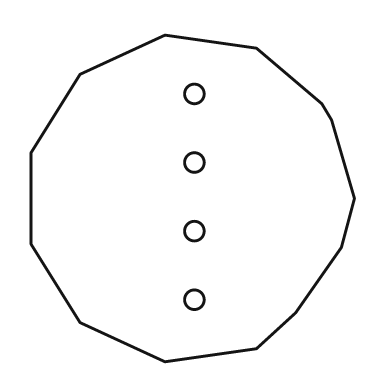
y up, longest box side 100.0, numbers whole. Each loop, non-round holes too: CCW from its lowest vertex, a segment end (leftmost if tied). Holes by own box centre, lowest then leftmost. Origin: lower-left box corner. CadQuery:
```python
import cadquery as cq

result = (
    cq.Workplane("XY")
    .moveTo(41.0, 0.0)
    .lineTo(69.0, 4.0)
    .lineTo(81.0, 15.0)
    .lineTo(95.0, 35.0)
    .lineTo(99.0, 50.0)
    .lineTo(92.0, 74.0)
    .lineTo(89.0, 79.0)
    .lineTo(69.0, 96.0)
    .lineTo(41.0, 100.0)
    .lineTo(15.0, 88.0)
    .lineTo(0.0, 64.0)
    .lineTo(0.0, 36.0)
    .lineTo(15.0, 12.0)
    .close()
    .moveTo(50.0, 19.0)
    .circle(3.0)
    .moveTo(50.0, 40.0)
    .circle(3.0)
    .moveTo(50.0, 61.0)
    .circle(3.0)
    .moveTo(50.0, 82.0)
    .circle(3.0)
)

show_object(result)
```